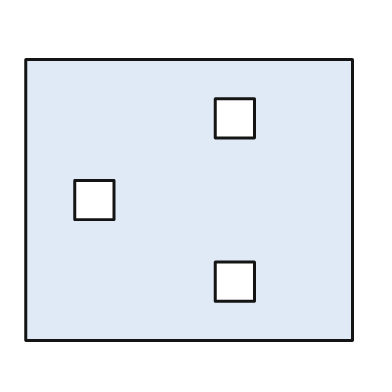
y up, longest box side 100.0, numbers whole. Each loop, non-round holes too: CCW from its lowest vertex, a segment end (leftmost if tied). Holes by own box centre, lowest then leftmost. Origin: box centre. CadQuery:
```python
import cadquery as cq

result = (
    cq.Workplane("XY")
    .moveTo(-50.0, -43.0)
    .lineTo(50.0, -43.0)
    .lineTo(50.0, 43.0)
    .lineTo(-50.0, 43.0)
    .close()
    .moveTo(8.0, -31.0)
    .lineTo(20.0, -31.0)
    .lineTo(20.0, -19.0)
    .lineTo(8.0, -19.0)
    .close()
    .moveTo(-35.0, -6.0)
    .lineTo(-23.0, -6.0)
    .lineTo(-23.0, 6.0)
    .lineTo(-35.0, 6.0)
    .close()
    .moveTo(8.0, 19.0)
    .lineTo(20.0, 19.0)
    .lineTo(20.0, 31.0)
    .lineTo(8.0, 31.0)
    .close()
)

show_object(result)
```